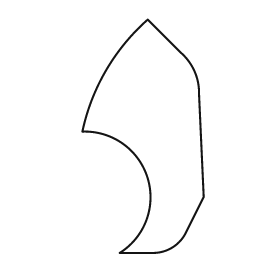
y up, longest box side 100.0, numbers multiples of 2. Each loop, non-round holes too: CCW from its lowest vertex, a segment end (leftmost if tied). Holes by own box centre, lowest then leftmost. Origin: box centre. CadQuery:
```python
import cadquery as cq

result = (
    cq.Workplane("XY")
    .moveTo(-10.0, -50.0)
    .lineTo(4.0, -50.0)
    .threePointArc((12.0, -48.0), (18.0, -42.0))
    .lineTo(26.0, -26.0)
    .lineTo(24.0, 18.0)
    .threePointArc((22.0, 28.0), (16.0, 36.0))
    .lineTo(2.0, 50.0)
    .threePointArc((-16.0, 28.0), (-26.0, 2.0))
    .threePointArc((2.0, -18.0), (-10.0, -50.0))
    .close()
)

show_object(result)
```